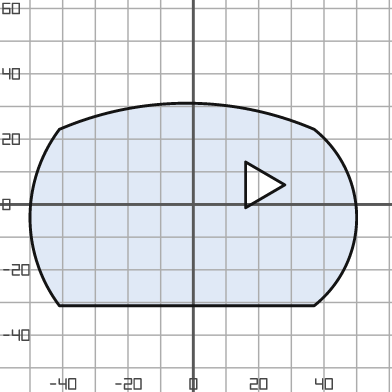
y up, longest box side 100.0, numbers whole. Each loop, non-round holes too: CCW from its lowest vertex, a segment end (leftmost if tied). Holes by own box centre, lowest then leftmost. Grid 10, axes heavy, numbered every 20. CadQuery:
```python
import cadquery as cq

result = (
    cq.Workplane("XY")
    .moveTo(-41.0, -31.0)
    .lineTo(37.0, -31.0)
    .threePointArc((50.0, -4.0), (37.0, 23.0))
    .threePointArc((-2.0, 31.0), (-41.0, 23.0))
    .threePointArc((-50.0, -4.0), (-41.0, -31.0))
    .close()
    .moveTo(16.0, -1.0)
    .lineTo(28.0, 6.0)
    .lineTo(16.0, 13.0)
    .close()
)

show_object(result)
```